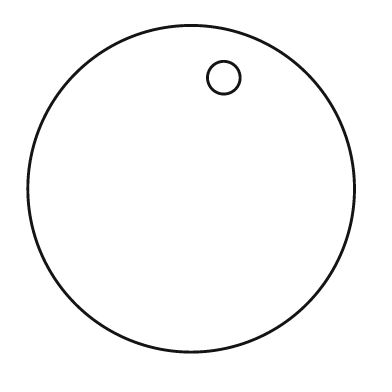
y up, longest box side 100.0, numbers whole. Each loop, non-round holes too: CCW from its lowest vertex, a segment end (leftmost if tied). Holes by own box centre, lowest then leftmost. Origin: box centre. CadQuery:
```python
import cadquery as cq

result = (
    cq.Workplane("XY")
    .moveTo(0.0, 0.0)
    .circle(50.0)
    .moveTo(10.0, 34.0)
    .circle(5.0)
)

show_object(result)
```